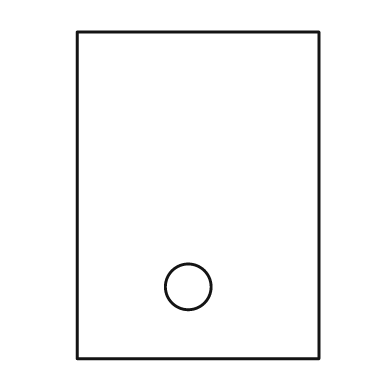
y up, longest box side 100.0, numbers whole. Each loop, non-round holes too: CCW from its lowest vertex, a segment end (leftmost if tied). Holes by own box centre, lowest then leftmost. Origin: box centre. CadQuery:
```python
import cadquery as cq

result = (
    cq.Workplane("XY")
    .moveTo(-37.0, -50.0)
    .lineTo(37.0, -50.0)
    .lineTo(37.0, 50.0)
    .lineTo(-37.0, 50.0)
    .close()
    .moveTo(-3.0, -28.0)
    .circle(7.0)
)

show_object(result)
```